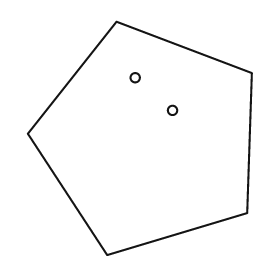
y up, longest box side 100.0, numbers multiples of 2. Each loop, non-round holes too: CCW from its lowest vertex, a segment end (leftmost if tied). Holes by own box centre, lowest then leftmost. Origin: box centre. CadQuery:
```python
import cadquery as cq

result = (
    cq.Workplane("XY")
    .moveTo(-14.0, -50.0)
    .lineTo(46.0, -32.0)
    .lineTo(48.0, 28.0)
    .lineTo(-10.0, 50.0)
    .lineTo(-48.0, 2.0)
    .close()
    .moveTo(14.0, 12.0)
    .circle(2.0)
    .moveTo(-2.0, 26.0)
    .circle(2.0)
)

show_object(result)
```